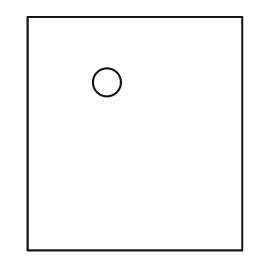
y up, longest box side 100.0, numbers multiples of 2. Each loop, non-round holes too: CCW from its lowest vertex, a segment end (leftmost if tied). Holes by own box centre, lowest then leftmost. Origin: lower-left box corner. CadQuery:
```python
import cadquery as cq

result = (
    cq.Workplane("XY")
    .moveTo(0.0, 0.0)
    .lineTo(92.0, 0.0)
    .lineTo(92.0, 100.0)
    .lineTo(0.0, 100.0)
    .close()
    .moveTo(34.0, 72.0)
    .circle(6.0)
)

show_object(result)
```